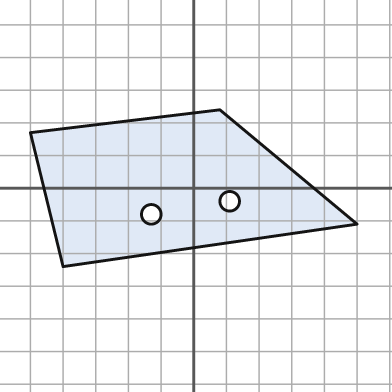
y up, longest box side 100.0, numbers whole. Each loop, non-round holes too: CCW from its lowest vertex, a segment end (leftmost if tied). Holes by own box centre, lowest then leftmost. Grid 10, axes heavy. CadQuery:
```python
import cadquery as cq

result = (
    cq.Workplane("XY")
    .moveTo(-40.0, -24.0)
    .lineTo(50.0, -11.0)
    .lineTo(8.0, 24.0)
    .lineTo(-50.0, 17.0)
    .close()
    .moveTo(-13.0, -8.0)
    .circle(3.0)
    .moveTo(11.0, -4.0)
    .circle(3.0)
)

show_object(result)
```